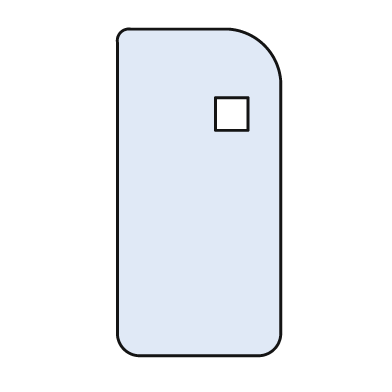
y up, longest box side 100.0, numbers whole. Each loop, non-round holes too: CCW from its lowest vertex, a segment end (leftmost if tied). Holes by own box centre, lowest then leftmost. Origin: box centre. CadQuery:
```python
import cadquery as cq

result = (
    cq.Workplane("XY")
    .moveTo(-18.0, -50.0)
    .lineTo(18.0, -50.0)
    .threePointArc((23.0, -48.0), (25.0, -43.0))
    .lineTo(25.0, 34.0)
    .threePointArc((20.0, 45.0), (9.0, 50.0))
    .lineTo(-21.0, 50.0)
    .threePointArc((-24.0, 49.0), (-25.0, 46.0))
    .lineTo(-25.0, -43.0)
    .threePointArc((-23.0, -48.0), (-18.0, -50.0))
    .close()
    .moveTo(5.0, 19.0)
    .lineTo(15.0, 19.0)
    .lineTo(15.0, 29.0)
    .lineTo(5.0, 29.0)
    .close()
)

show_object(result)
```